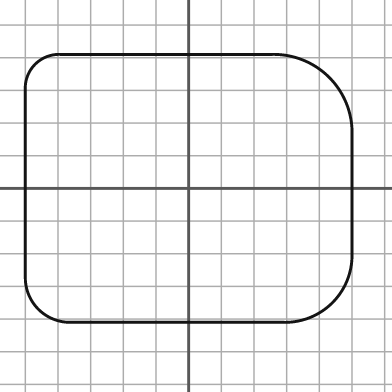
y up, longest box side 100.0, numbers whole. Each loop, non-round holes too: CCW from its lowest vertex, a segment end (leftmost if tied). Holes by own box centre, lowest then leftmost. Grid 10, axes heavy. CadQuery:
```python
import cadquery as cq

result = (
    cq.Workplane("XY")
    .moveTo(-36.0, -41.0)
    .lineTo(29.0, -41.0)
    .threePointArc((44.0, -35.0), (50.0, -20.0))
    .lineTo(50.0, 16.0)
    .threePointArc((43.0, 34.0), (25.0, 41.0))
    .lineTo(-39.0, 41.0)
    .threePointArc((-47.0, 38.0), (-50.0, 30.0))
    .lineTo(-50.0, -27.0)
    .threePointArc((-46.0, -37.0), (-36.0, -41.0))
    .close()
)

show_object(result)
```